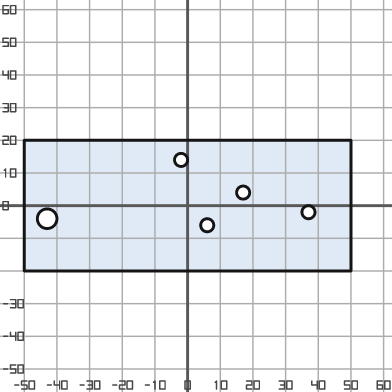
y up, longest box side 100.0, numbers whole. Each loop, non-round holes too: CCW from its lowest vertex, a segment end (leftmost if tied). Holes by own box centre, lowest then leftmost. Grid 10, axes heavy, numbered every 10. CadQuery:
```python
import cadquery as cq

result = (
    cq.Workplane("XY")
    .moveTo(-50.0, -20.0)
    .lineTo(50.0, -20.0)
    .lineTo(50.0, 20.0)
    .lineTo(-50.0, 20.0)
    .close()
    .moveTo(6.0, -6.0)
    .circle(2.0)
    .moveTo(-43.0, -4.0)
    .circle(3.0)
    .moveTo(37.0, -2.0)
    .circle(2.0)
    .moveTo(17.0, 4.0)
    .circle(2.0)
    .moveTo(-2.0, 14.0)
    .circle(2.0)
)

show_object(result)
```